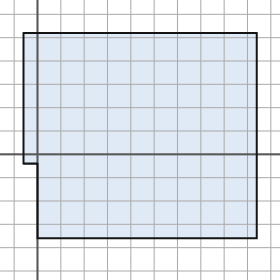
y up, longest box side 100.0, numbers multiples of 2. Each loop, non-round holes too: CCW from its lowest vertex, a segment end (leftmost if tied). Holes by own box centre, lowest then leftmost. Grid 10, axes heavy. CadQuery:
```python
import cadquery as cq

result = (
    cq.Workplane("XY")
    .moveTo(0.0, -36.0)
    .lineTo(94.0, -36.0)
    .lineTo(94.0, 52.0)
    .lineTo(-6.0, 52.0)
    .lineTo(-6.0, -4.0)
    .lineTo(0.0, -4.0)
    .close()
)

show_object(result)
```